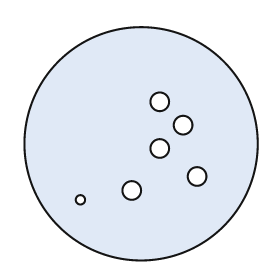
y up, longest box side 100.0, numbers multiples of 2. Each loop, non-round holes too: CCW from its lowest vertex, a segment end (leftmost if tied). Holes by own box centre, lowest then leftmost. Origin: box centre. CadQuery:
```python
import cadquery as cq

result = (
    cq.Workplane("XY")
    .moveTo(0.0, 0.0)
    .circle(50.0)
    .moveTo(-26.0, -24.0)
    .circle(2.0)
    .moveTo(-4.0, -20.0)
    .circle(4.0)
    .moveTo(24.0, -14.0)
    .circle(4.0)
    .moveTo(8.0, -2.0)
    .circle(4.0)
    .moveTo(18.0, 8.0)
    .circle(4.0)
    .moveTo(8.0, 18.0)
    .circle(4.0)
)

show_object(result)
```